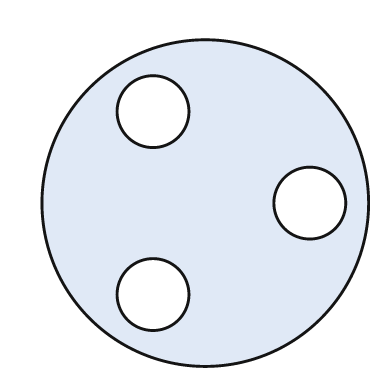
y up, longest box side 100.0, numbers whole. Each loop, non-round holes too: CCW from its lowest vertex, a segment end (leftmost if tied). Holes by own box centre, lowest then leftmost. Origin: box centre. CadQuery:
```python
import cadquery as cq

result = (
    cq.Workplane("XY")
    .moveTo(0.0, 0.0)
    .circle(50.0)
    .moveTo(-16.0, -28.0)
    .circle(11.0)
    .moveTo(32.0, 0.0)
    .circle(11.0)
    .moveTo(-16.0, 28.0)
    .circle(11.0)
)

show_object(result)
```